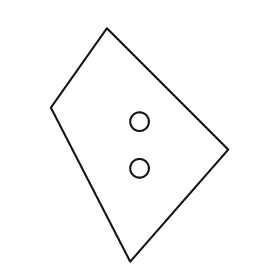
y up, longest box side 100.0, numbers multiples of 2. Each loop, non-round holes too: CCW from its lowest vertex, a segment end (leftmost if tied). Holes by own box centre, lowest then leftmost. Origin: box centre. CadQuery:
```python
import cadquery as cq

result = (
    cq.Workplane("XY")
    .moveTo(-4.0, -50.0)
    .lineTo(38.0, -2.0)
    .lineTo(-14.0, 50.0)
    .lineTo(-38.0, 16.0)
    .close()
    .moveTo(0.0, -10.0)
    .circle(4.0)
    .moveTo(0.0, 10.0)
    .circle(4.0)
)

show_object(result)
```